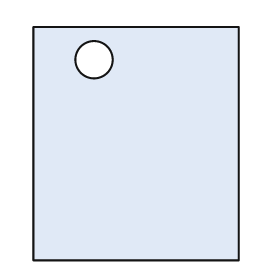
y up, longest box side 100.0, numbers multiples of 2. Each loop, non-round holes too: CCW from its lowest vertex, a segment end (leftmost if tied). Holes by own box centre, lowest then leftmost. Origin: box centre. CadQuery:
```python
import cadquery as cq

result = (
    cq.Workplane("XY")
    .moveTo(-44.0, -50.0)
    .lineTo(44.0, -50.0)
    .lineTo(44.0, 50.0)
    .lineTo(-44.0, 50.0)
    .close()
    .moveTo(-18.0, 36.0)
    .circle(8.0)
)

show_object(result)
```